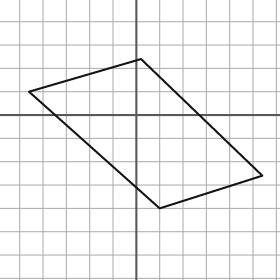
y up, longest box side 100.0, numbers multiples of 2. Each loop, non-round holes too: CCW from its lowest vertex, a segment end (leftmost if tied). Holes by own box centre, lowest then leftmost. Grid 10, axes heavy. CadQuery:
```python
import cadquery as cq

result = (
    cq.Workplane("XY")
    .moveTo(10.0, -40.0)
    .lineTo(54.0, -26.0)
    .lineTo(2.0, 24.0)
    .lineTo(-46.0, 10.0)
    .close()
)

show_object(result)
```